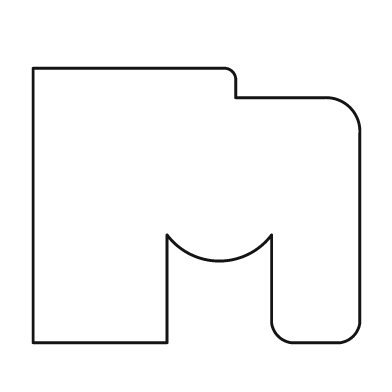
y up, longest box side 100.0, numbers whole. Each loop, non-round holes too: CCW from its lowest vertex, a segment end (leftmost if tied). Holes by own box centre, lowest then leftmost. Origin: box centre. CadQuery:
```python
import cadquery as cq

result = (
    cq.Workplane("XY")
    .moveTo(-50.0, -42.0)
    .lineTo(-9.0, -42.0)
    .lineTo(-9.0, -9.0)
    .threePointArc((7.0, -17.0), (23.0, -9.0))
    .lineTo(23.0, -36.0)
    .threePointArc((25.0, -40.0), (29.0, -42.0))
    .lineTo(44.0, -42.0)
    .threePointArc((48.0, -40.0), (50.0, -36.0))
    .lineTo(50.0, 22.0)
    .threePointArc((47.0, 30.0), (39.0, 33.0))
    .lineTo(12.0, 33.0)
    .lineTo(12.0, 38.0)
    .threePointArc((11.0, 41.0), (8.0, 42.0))
    .lineTo(-50.0, 42.0)
    .close()
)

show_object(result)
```